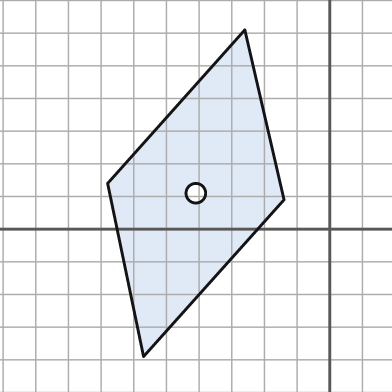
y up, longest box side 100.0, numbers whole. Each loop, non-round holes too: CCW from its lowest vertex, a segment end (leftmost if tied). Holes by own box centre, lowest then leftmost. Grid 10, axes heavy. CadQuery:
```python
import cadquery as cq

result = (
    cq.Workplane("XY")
    .moveTo(-57.0, -39.0)
    .lineTo(-14.0, 9.0)
    .lineTo(-26.0, 61.0)
    .lineTo(-68.0, 14.0)
    .close()
    .moveTo(-41.0, 11.0)
    .circle(3.0)
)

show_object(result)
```